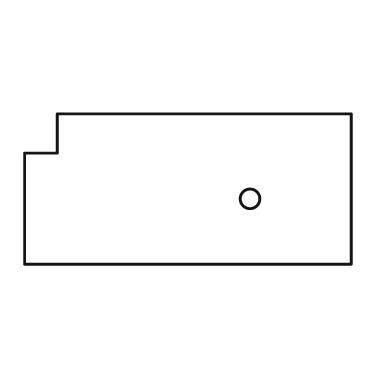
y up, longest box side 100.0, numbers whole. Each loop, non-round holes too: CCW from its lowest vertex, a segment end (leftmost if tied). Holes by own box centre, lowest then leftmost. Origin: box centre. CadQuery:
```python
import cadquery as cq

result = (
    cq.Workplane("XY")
    .moveTo(-50.0, -23.0)
    .lineTo(50.0, -23.0)
    .lineTo(50.0, 23.0)
    .lineTo(-40.0, 23.0)
    .lineTo(-40.0, 11.0)
    .lineTo(-50.0, 11.0)
    .close()
    .moveTo(19.0, -3.0)
    .circle(3.0)
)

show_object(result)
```